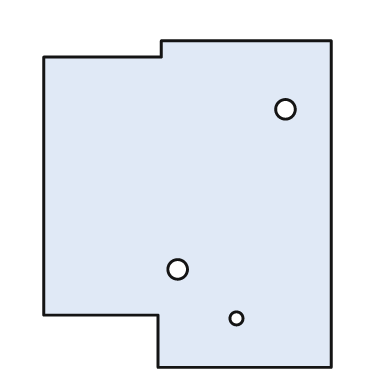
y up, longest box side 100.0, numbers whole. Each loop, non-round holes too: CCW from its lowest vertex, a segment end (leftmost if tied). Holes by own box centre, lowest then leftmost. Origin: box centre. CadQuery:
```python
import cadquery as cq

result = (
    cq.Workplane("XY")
    .moveTo(-9.0, -50.0)
    .lineTo(44.0, -50.0)
    .lineTo(44.0, 50.0)
    .lineTo(-8.0, 50.0)
    .lineTo(-8.0, 45.0)
    .lineTo(-44.0, 45.0)
    .lineTo(-44.0, -34.0)
    .lineTo(-9.0, -34.0)
    .close()
    .moveTo(15.0, -35.0)
    .circle(2.0)
    .moveTo(-3.0, -20.0)
    .circle(3.0)
    .moveTo(30.0, 29.0)
    .circle(3.0)
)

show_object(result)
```